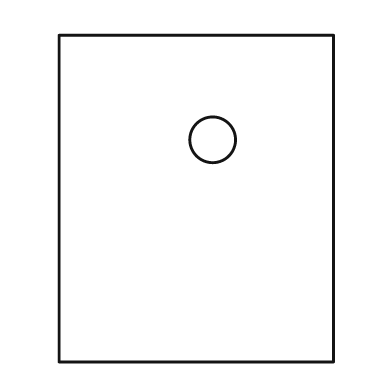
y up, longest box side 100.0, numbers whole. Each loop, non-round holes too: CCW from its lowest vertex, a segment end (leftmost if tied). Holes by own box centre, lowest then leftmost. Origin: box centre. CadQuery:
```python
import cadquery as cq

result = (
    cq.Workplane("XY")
    .moveTo(-42.0, -50.0)
    .lineTo(42.0, -50.0)
    .lineTo(42.0, 50.0)
    .lineTo(-42.0, 50.0)
    .close()
    .moveTo(5.0, 18.0)
    .circle(7.0)
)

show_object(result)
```